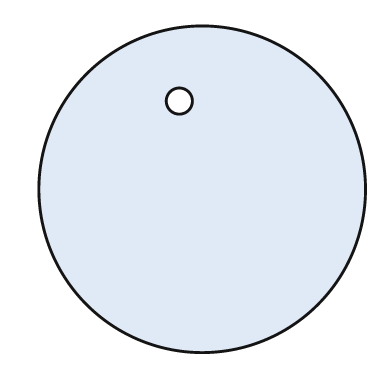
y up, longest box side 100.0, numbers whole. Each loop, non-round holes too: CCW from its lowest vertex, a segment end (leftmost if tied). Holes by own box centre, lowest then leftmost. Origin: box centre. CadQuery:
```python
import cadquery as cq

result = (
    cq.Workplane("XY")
    .moveTo(0.0, 0.0)
    .circle(50.0)
    .moveTo(-7.0, 27.0)
    .circle(4.0)
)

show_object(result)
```